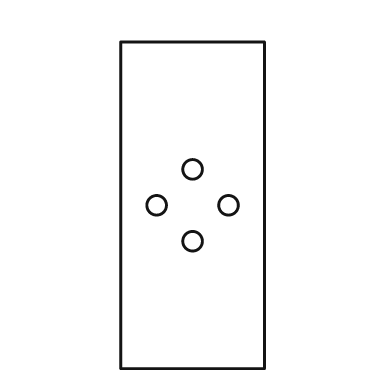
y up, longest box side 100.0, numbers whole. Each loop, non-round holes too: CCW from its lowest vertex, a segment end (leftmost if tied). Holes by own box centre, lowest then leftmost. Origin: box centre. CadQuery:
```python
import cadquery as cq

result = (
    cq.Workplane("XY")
    .moveTo(-22.0, -50.0)
    .lineTo(22.0, -50.0)
    .lineTo(22.0, 50.0)
    .lineTo(-22.0, 50.0)
    .close()
    .moveTo(0.0, -11.0)
    .circle(3.0)
    .moveTo(-11.0, 0.0)
    .circle(3.0)
    .moveTo(11.0, 0.0)
    .circle(3.0)
    .moveTo(0.0, 11.0)
    .circle(3.0)
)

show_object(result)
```